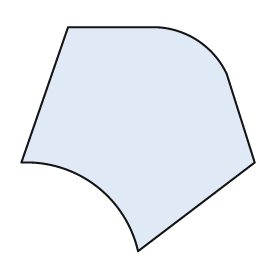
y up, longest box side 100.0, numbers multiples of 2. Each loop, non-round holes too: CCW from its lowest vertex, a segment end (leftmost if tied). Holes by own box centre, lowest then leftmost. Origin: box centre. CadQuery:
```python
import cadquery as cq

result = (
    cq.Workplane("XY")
    .moveTo(0.0, -48.0)
    .lineTo(50.0, -10.0)
    .lineTo(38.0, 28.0)
    .threePointArc((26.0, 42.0), (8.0, 48.0))
    .lineTo(-30.0, 48.0)
    .lineTo(-50.0, -10.0)
    .threePointArc((-18.0, -20.0), (0.0, -48.0))
    .close()
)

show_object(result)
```